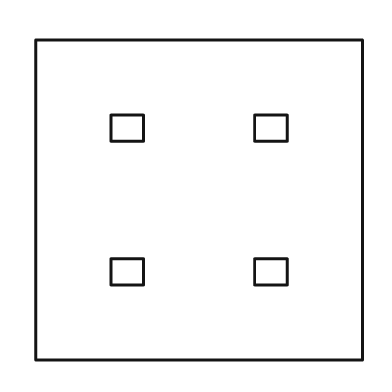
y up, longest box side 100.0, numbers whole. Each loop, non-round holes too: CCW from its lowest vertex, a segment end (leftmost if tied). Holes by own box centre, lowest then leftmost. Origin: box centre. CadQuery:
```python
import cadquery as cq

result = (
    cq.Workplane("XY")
    .moveTo(-50.0, -49.0)
    .lineTo(50.0, -49.0)
    .lineTo(50.0, 49.0)
    .lineTo(-50.0, 49.0)
    .close()
    .moveTo(-27.0, -26.0)
    .lineTo(-17.0, -26.0)
    .lineTo(-17.0, -18.0)
    .lineTo(-27.0, -18.0)
    .close()
    .moveTo(17.0, -26.0)
    .lineTo(27.0, -26.0)
    .lineTo(27.0, -18.0)
    .lineTo(17.0, -18.0)
    .close()
    .moveTo(-27.0, 18.0)
    .lineTo(-17.0, 18.0)
    .lineTo(-17.0, 26.0)
    .lineTo(-27.0, 26.0)
    .close()
    .moveTo(17.0, 18.0)
    .lineTo(27.0, 18.0)
    .lineTo(27.0, 26.0)
    .lineTo(17.0, 26.0)
    .close()
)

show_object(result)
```